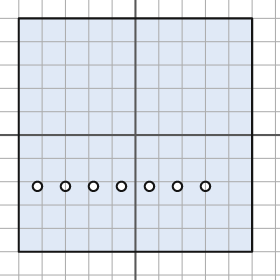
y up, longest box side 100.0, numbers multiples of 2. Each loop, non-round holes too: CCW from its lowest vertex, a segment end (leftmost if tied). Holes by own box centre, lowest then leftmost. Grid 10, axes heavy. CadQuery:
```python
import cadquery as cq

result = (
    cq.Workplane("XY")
    .moveTo(-50.0, -50.0)
    .lineTo(50.0, -50.0)
    .lineTo(50.0, 50.0)
    .lineTo(-50.0, 50.0)
    .close()
    .moveTo(-42.0, -22.0)
    .circle(2.0)
    .moveTo(-30.0, -22.0)
    .circle(2.0)
    .moveTo(-18.0, -22.0)
    .circle(2.0)
    .moveTo(-6.0, -22.0)
    .circle(2.0)
    .moveTo(6.0, -22.0)
    .circle(2.0)
    .moveTo(18.0, -22.0)
    .circle(2.0)
    .moveTo(30.0, -22.0)
    .circle(2.0)
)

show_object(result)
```